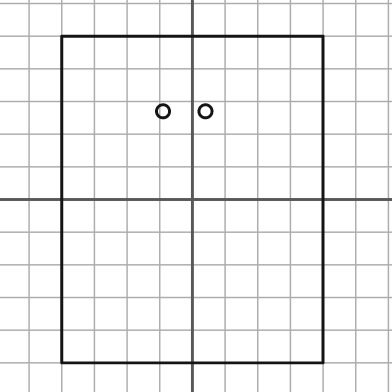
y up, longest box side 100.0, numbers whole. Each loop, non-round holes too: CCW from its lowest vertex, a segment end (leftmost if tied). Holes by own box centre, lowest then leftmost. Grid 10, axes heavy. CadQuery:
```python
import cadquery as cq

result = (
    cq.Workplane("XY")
    .moveTo(-40.0, -50.0)
    .lineTo(40.0, -50.0)
    .lineTo(40.0, 50.0)
    .lineTo(-40.0, 50.0)
    .close()
    .moveTo(-9.0, 27.0)
    .circle(2.0)
    .moveTo(4.0, 27.0)
    .circle(2.0)
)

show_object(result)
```